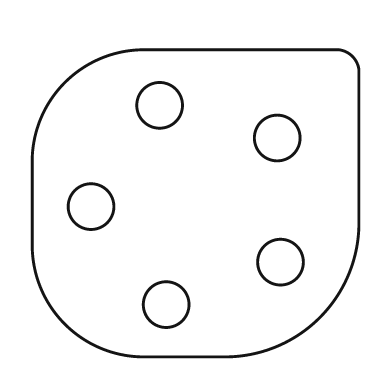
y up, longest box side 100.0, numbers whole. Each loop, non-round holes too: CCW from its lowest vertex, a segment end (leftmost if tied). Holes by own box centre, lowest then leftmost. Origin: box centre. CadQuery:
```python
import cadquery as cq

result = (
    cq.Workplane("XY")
    .moveTo(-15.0, -47.0)
    .lineTo(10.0, -47.0)
    .threePointArc((38.0, -35.0), (50.0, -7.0))
    .lineTo(50.0, 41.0)
    .threePointArc((48.0, 45.0), (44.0, 47.0))
    .lineTo(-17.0, 47.0)
    .threePointArc((-40.0, 37.0), (-50.0, 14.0))
    .lineTo(-50.0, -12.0)
    .threePointArc((-40.0, -37.0), (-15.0, -47.0))
    .close()
    .moveTo(-9.0, -31.0)
    .circle(7.0)
    .moveTo(26.0, -18.0)
    .circle(7.0)
    .moveTo(-32.0, -1.0)
    .circle(7.0)
    .moveTo(25.0, 20.0)
    .circle(7.0)
    .moveTo(-11.0, 30.0)
    .circle(7.0)
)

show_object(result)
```